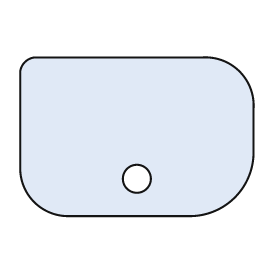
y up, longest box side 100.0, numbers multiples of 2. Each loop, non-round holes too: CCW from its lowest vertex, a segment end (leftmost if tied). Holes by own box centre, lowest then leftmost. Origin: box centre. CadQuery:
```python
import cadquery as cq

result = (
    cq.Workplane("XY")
    .moveTo(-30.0, -34.0)
    .lineTo(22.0, -34.0)
    .threePointArc((42.0, -26.0), (50.0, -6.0))
    .lineTo(50.0, 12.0)
    .threePointArc((44.0, 28.0), (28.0, 34.0))
    .lineTo(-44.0, 34.0)
    .threePointArc((-48.0, 32.0), (-50.0, 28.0))
    .lineTo(-50.0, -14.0)
    .threePointArc((-44.0, -28.0), (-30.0, -34.0))
    .close()
    .moveTo(0.0, -18.0)
    .circle(6.0)
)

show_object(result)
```